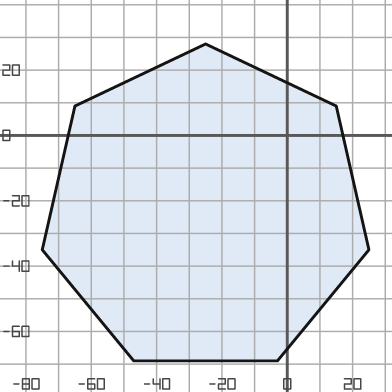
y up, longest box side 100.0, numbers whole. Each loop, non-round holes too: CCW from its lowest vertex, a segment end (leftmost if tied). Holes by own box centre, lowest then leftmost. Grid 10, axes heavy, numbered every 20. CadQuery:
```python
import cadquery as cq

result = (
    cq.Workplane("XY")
    .moveTo(-47.0, -69.0)
    .lineTo(-3.0, -69.0)
    .lineTo(25.0, -35.0)
    .lineTo(15.0, 9.0)
    .lineTo(-25.0, 28.0)
    .lineTo(-65.0, 9.0)
    .lineTo(-75.0, -35.0)
    .close()
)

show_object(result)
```